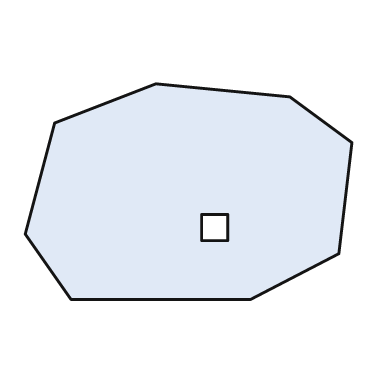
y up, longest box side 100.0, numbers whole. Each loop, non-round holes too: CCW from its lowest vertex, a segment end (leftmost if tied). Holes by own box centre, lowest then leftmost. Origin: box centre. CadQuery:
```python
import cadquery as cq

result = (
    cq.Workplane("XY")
    .moveTo(-36.0, -33.0)
    .lineTo(19.0, -33.0)
    .lineTo(46.0, -19.0)
    .lineTo(50.0, 15.0)
    .lineTo(31.0, 29.0)
    .lineTo(-10.0, 33.0)
    .lineTo(-41.0, 21.0)
    .lineTo(-50.0, -13.0)
    .close()
    .moveTo(4.0, -15.0)
    .lineTo(12.0, -15.0)
    .lineTo(12.0, -7.0)
    .lineTo(4.0, -7.0)
    .close()
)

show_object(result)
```